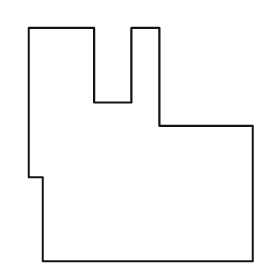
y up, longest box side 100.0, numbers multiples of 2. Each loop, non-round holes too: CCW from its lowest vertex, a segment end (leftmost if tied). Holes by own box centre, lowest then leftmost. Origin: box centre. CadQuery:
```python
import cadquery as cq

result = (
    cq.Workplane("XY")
    .moveTo(-42.0, -50.0)
    .lineTo(48.0, -50.0)
    .lineTo(48.0, 8.0)
    .lineTo(8.0, 8.0)
    .lineTo(8.0, 50.0)
    .lineTo(-4.0, 50.0)
    .lineTo(-4.0, 18.0)
    .lineTo(-20.0, 18.0)
    .lineTo(-20.0, 50.0)
    .lineTo(-48.0, 50.0)
    .lineTo(-48.0, -14.0)
    .lineTo(-42.0, -14.0)
    .close()
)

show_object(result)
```